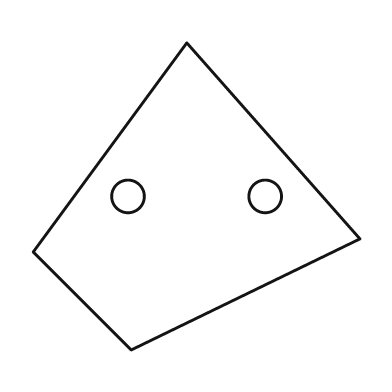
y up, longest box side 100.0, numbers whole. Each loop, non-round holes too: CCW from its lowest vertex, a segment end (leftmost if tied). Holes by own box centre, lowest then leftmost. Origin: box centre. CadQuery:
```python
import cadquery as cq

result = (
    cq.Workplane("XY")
    .moveTo(-20.0, -47.0)
    .lineTo(50.0, -13.0)
    .lineTo(-3.0, 47.0)
    .lineTo(-50.0, -17.0)
    .close()
    .moveTo(-21.0, 0.0)
    .circle(5.0)
    .moveTo(21.0, 0.0)
    .circle(5.0)
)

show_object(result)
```